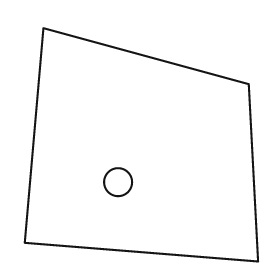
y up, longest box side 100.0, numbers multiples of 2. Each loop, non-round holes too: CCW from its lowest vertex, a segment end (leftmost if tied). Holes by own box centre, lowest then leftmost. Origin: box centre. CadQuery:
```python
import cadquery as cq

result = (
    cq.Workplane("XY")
    .moveTo(50.0, -50.0)
    .lineTo(46.0, 26.0)
    .lineTo(-42.0, 50.0)
    .lineTo(-50.0, -42.0)
    .close()
    .moveTo(-10.0, -16.0)
    .circle(6.0)
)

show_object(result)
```